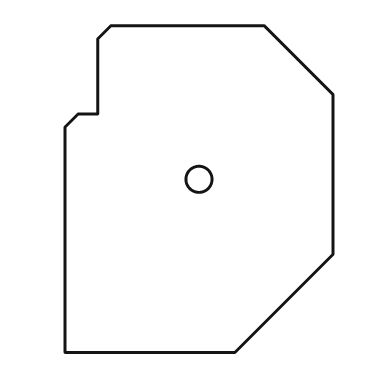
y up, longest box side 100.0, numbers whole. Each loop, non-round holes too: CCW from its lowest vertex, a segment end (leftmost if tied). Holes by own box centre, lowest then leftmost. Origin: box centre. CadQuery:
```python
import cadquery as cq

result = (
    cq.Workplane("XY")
    .moveTo(-41.0, -50.0)
    .lineTo(11.0, -50.0)
    .lineTo(41.0, -20.0)
    .lineTo(41.0, 29.0)
    .lineTo(20.0, 50.0)
    .lineTo(-27.0, 50.0)
    .lineTo(-31.0, 46.0)
    .lineTo(-31.0, 23.0)
    .lineTo(-37.0, 23.0)
    .lineTo(-41.0, 19.0)
    .close()
    .moveTo(0.0, 3.0)
    .circle(4.0)
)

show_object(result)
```